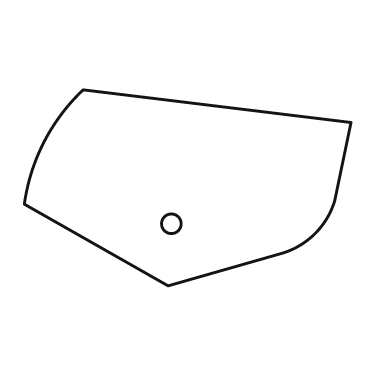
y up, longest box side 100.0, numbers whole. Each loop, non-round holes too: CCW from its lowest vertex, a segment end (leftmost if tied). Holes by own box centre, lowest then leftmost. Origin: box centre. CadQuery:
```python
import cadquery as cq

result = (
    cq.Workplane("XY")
    .moveTo(-6.0, -30.0)
    .lineTo(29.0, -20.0)
    .threePointArc((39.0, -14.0), (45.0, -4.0))
    .lineTo(50.0, 20.0)
    .lineTo(-32.0, 30.0)
    .threePointArc((-44.0, 14.0), (-50.0, -5.0))
    .close()
    .moveTo(-5.0, -11.0)
    .circle(3.0)
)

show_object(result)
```